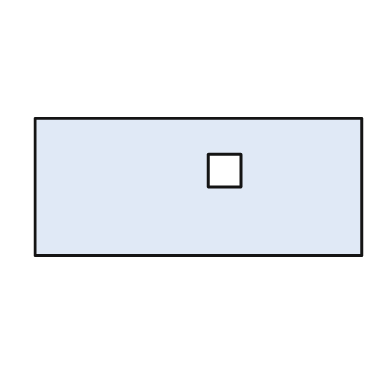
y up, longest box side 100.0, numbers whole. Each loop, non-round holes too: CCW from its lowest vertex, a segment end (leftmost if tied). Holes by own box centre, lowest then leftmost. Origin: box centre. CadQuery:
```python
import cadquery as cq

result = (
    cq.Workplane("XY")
    .moveTo(-50.0, -21.0)
    .lineTo(50.0, -21.0)
    .lineTo(50.0, 21.0)
    .lineTo(-50.0, 21.0)
    .close()
    .moveTo(3.0, 0.0)
    .lineTo(13.0, 0.0)
    .lineTo(13.0, 10.0)
    .lineTo(3.0, 10.0)
    .close()
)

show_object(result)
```